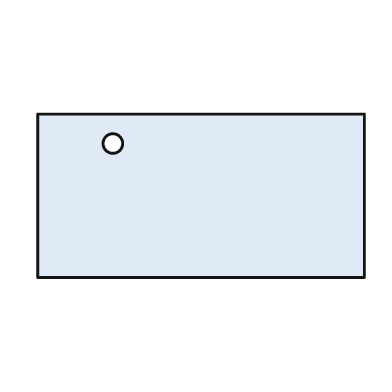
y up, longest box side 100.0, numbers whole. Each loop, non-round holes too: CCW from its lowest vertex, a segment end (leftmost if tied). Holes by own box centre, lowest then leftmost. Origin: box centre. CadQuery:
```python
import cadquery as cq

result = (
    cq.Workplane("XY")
    .moveTo(-50.0, -25.0)
    .lineTo(50.0, -25.0)
    .lineTo(50.0, 25.0)
    .lineTo(-50.0, 25.0)
    .close()
    .moveTo(-27.0, 16.0)
    .circle(3.0)
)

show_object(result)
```